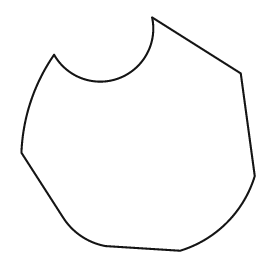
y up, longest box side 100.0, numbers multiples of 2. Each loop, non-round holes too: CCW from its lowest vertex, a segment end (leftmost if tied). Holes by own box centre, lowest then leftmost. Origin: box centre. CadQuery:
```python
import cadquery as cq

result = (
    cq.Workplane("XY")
    .moveTo(18.0, -50.0)
    .threePointArc((38.0, -38.0), (50.0, -18.0))
    .lineTo(44.0, 26.0)
    .lineTo(6.0, 50.0)
    .threePointArc((-8.0, 24.0), (-36.0, 34.0))
    .threePointArc((-46.0, 14.0), (-50.0, -8.0))
    .lineTo(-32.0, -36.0)
    .threePointArc((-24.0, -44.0), (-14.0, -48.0))
    .close()
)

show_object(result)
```